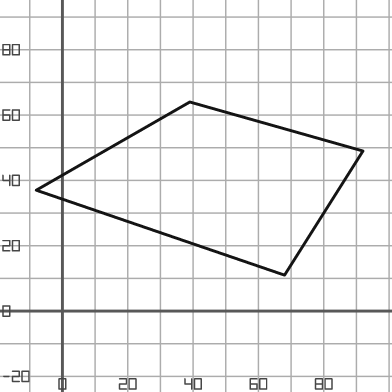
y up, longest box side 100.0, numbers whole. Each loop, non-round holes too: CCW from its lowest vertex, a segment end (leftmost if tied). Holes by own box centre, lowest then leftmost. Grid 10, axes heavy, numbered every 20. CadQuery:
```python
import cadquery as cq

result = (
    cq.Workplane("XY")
    .moveTo(68.0, 11.0)
    .lineTo(92.0, 49.0)
    .lineTo(39.0, 64.0)
    .lineTo(-8.0, 37.0)
    .close()
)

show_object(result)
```